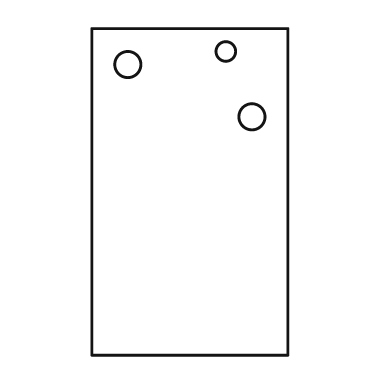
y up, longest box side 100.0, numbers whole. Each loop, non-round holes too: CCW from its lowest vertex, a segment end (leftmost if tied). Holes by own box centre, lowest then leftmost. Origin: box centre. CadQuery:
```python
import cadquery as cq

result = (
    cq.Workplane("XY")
    .moveTo(-30.0, -50.0)
    .lineTo(30.0, -50.0)
    .lineTo(30.0, 50.0)
    .lineTo(-30.0, 50.0)
    .close()
    .moveTo(19.0, 23.0)
    .circle(4.0)
    .moveTo(-19.0, 39.0)
    .circle(4.0)
    .moveTo(11.0, 43.0)
    .circle(3.0)
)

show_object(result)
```